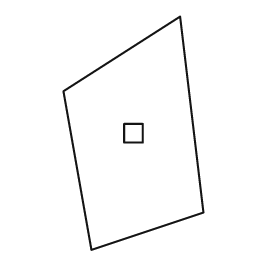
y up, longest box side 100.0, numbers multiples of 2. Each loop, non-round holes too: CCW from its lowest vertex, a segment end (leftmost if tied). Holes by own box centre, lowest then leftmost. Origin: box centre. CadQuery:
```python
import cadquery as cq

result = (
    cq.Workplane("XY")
    .moveTo(-18.0, -50.0)
    .lineTo(30.0, -34.0)
    .lineTo(20.0, 50.0)
    .lineTo(-30.0, 18.0)
    .close()
    .moveTo(-4.0, -4.0)
    .lineTo(4.0, -4.0)
    .lineTo(4.0, 4.0)
    .lineTo(-4.0, 4.0)
    .close()
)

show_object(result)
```